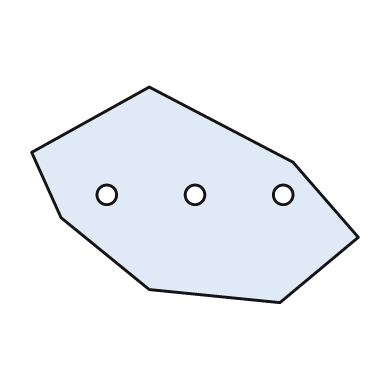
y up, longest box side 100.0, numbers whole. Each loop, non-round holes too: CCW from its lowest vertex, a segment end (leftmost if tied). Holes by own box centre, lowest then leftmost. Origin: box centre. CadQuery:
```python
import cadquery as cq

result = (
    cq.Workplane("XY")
    .moveTo(26.0, -33.0)
    .lineTo(50.0, -13.0)
    .lineTo(30.0, 10.0)
    .lineTo(-14.0, 33.0)
    .lineTo(-50.0, 13.0)
    .lineTo(-41.0, -7.0)
    .lineTo(-14.0, -29.0)
    .close()
    .moveTo(-27.0, 0.0)
    .circle(3.0)
    .moveTo(0.0, 0.0)
    .circle(3.0)
    .moveTo(27.0, 0.0)
    .circle(3.0)
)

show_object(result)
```